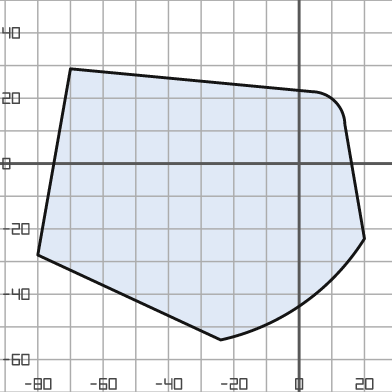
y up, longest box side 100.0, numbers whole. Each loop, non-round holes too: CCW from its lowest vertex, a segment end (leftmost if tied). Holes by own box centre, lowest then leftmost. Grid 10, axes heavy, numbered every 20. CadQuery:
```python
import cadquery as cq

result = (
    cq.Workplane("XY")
    .moveTo(-24.0, -54.0)
    .threePointArc((1.0, -43.0), (20.0, -23.0))
    .lineTo(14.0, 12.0)
    .threePointArc((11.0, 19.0), (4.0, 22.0))
    .lineTo(-70.0, 29.0)
    .lineTo(-80.0, -28.0)
    .close()
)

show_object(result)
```